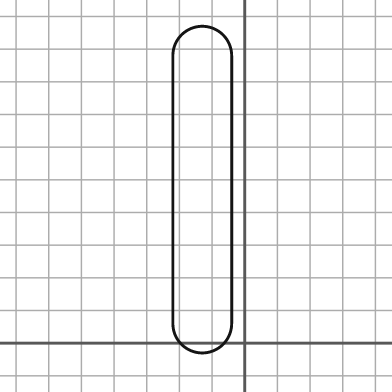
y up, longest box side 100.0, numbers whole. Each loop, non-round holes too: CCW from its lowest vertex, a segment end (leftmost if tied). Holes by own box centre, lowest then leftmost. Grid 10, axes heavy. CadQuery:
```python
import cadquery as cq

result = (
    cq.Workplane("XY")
    .moveTo(-22.0, 6.0)
    .threePointArc((-13.0, -3.0), (-4.0, 6.0))
    .lineTo(-4.0, 88.0)
    .threePointArc((-13.0, 97.0), (-22.0, 88.0))
    .close()
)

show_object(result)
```